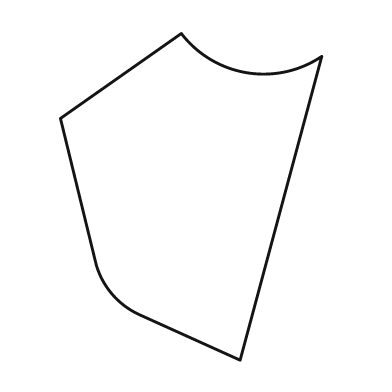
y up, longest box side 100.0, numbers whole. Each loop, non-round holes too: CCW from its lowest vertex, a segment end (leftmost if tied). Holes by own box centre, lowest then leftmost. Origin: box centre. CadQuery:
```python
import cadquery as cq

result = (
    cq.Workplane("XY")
    .moveTo(15.0, -50.0)
    .lineTo(40.0, 43.0)
    .threePointArc((17.0, 38.0), (-3.0, 50.0))
    .lineTo(-40.0, 24.0)
    .lineTo(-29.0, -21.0)
    .threePointArc((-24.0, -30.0), (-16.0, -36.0))
    .close()
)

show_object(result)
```